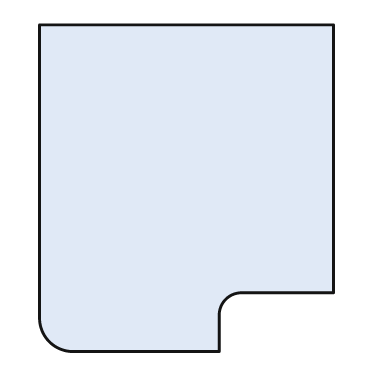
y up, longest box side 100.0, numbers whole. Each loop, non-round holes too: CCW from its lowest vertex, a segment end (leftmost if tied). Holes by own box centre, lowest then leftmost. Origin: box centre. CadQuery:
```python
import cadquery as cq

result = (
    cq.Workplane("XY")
    .moveTo(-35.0, -50.0)
    .lineTo(10.0, -50.0)
    .lineTo(10.0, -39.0)
    .threePointArc((12.0, -34.0), (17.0, -32.0))
    .lineTo(45.0, -32.0)
    .lineTo(45.0, 50.0)
    .lineTo(-45.0, 50.0)
    .lineTo(-45.0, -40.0)
    .threePointArc((-42.0, -47.0), (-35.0, -50.0))
    .close()
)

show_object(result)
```